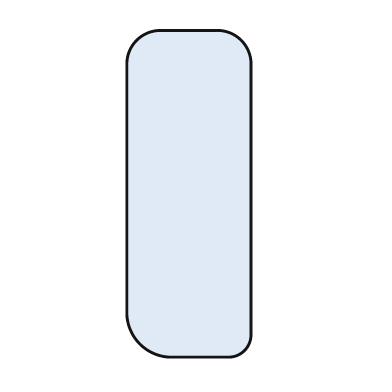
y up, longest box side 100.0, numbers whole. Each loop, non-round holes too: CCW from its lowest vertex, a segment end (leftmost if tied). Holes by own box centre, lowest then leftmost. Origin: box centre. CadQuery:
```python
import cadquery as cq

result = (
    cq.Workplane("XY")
    .moveTo(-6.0, -50.0)
    .lineTo(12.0, -50.0)
    .threePointArc((17.0, -48.0), (19.0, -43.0))
    .lineTo(19.0, 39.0)
    .threePointArc((16.0, 47.0), (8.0, 50.0))
    .lineTo(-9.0, 50.0)
    .threePointArc((-16.0, 47.0), (-19.0, 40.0))
    .lineTo(-19.0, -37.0)
    .threePointArc((-15.0, -46.0), (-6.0, -50.0))
    .close()
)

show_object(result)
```